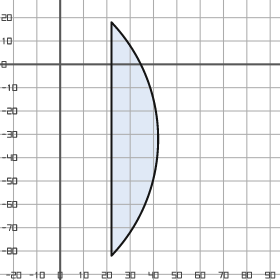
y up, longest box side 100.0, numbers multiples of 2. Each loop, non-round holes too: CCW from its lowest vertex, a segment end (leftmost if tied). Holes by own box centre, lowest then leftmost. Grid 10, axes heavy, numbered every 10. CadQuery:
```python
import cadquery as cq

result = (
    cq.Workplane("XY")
    .moveTo(22.0, -82.0)
    .threePointArc((42.0, -32.0), (22.0, 18.0))
    .close()
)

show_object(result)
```